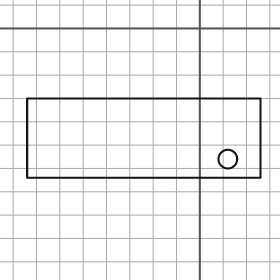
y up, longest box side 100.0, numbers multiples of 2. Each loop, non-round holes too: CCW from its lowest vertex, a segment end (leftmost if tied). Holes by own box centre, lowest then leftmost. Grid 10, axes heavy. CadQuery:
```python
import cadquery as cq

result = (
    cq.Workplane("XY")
    .moveTo(-74.0, -64.0)
    .lineTo(26.0, -64.0)
    .lineTo(26.0, -30.0)
    .lineTo(-74.0, -30.0)
    .close()
    .moveTo(12.0, -56.0)
    .circle(4.0)
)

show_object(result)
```